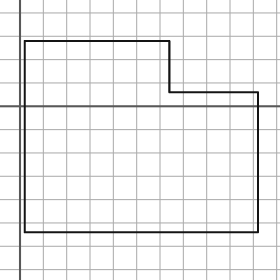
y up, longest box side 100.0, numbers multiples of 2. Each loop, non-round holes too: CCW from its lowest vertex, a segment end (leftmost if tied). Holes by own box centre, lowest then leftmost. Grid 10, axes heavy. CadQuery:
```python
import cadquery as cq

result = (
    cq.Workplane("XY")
    .moveTo(2.0, -54.0)
    .lineTo(102.0, -54.0)
    .lineTo(102.0, 6.0)
    .lineTo(64.0, 6.0)
    .lineTo(64.0, 28.0)
    .lineTo(2.0, 28.0)
    .close()
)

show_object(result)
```